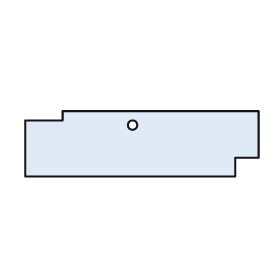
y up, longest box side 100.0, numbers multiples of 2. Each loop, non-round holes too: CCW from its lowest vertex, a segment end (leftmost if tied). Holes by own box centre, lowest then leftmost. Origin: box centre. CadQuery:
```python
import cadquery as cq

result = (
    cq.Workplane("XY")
    .moveTo(-50.0, -14.0)
    .lineTo(40.0, -14.0)
    .lineTo(40.0, -6.0)
    .lineTo(50.0, -6.0)
    .lineTo(50.0, 14.0)
    .lineTo(-34.0, 14.0)
    .lineTo(-34.0, 10.0)
    .lineTo(-50.0, 10.0)
    .close()
    .moveTo(-4.0, 8.0)
    .circle(2.0)
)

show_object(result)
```